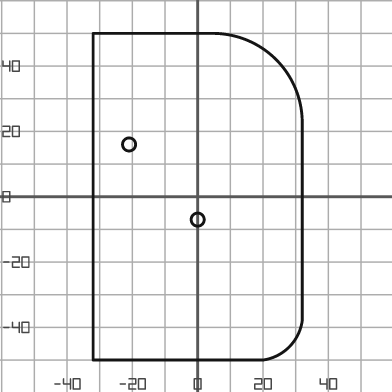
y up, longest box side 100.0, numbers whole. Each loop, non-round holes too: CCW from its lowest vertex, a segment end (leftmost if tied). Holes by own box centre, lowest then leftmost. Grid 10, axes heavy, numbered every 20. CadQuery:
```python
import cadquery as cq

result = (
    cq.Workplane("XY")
    .moveTo(-32.0, -50.0)
    .lineTo(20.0, -50.0)
    .threePointArc((28.0, -46.0), (32.0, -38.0))
    .lineTo(32.0, 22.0)
    .threePointArc((24.0, 42.0), (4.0, 50.0))
    .lineTo(-32.0, 50.0)
    .close()
    .moveTo(0.0, -7.0)
    .circle(2.0)
    .moveTo(-21.0, 16.0)
    .circle(2.0)
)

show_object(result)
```